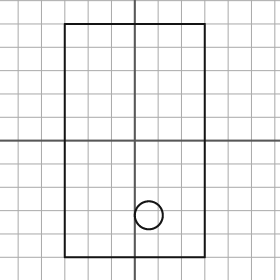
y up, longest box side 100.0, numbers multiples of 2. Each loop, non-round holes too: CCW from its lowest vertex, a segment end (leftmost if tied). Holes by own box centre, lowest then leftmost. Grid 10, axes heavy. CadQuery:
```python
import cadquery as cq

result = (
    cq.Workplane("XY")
    .moveTo(-30.0, -50.0)
    .lineTo(30.0, -50.0)
    .lineTo(30.0, 50.0)
    .lineTo(-30.0, 50.0)
    .close()
    .moveTo(6.0, -32.0)
    .circle(6.0)
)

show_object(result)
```